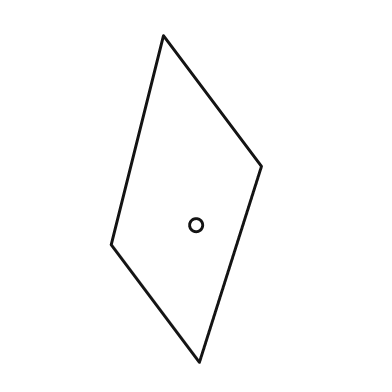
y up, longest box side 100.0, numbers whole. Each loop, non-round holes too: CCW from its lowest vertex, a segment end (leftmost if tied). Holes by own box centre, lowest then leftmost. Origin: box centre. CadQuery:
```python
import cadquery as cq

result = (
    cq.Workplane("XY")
    .moveTo(4.0, -50.0)
    .lineTo(23.0, 10.0)
    .lineTo(-7.0, 50.0)
    .lineTo(-23.0, -14.0)
    .close()
    .moveTo(3.0, -8.0)
    .circle(2.0)
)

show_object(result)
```